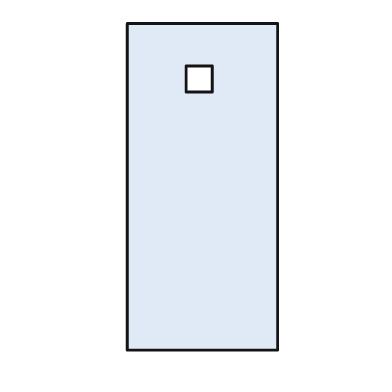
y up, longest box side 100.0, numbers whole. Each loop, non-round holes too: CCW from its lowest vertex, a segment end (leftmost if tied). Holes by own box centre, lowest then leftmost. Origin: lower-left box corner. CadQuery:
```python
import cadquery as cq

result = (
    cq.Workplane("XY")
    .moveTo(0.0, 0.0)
    .lineTo(46.0, 0.0)
    .lineTo(46.0, 100.0)
    .lineTo(0.0, 100.0)
    .close()
    .moveTo(18.0, 79.0)
    .lineTo(26.0, 79.0)
    .lineTo(26.0, 87.0)
    .lineTo(18.0, 87.0)
    .close()
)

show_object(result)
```